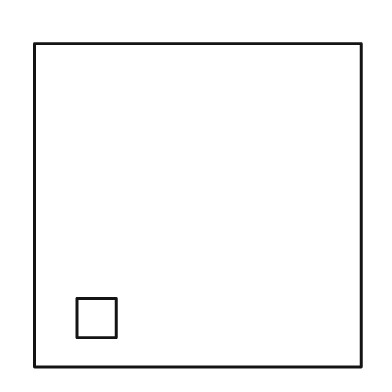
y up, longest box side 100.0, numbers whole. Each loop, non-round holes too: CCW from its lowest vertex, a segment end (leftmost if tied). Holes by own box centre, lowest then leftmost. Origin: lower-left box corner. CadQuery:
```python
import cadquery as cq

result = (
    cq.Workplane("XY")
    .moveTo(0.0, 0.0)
    .lineTo(100.0, 0.0)
    .lineTo(100.0, 99.0)
    .lineTo(0.0, 99.0)
    .close()
    .moveTo(13.0, 9.0)
    .lineTo(25.0, 9.0)
    .lineTo(25.0, 21.0)
    .lineTo(13.0, 21.0)
    .close()
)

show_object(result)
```